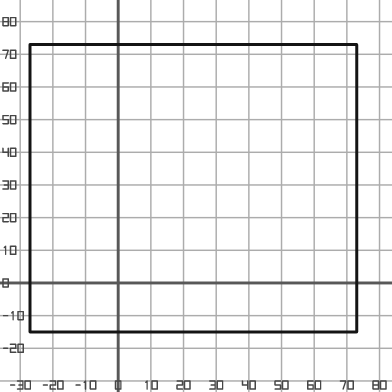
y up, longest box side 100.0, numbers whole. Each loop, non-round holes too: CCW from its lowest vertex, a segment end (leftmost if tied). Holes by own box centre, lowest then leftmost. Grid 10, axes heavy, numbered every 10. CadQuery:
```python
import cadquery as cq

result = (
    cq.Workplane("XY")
    .moveTo(-27.0, -15.0)
    .lineTo(73.0, -15.0)
    .lineTo(73.0, 73.0)
    .lineTo(-27.0, 73.0)
    .close()
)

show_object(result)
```